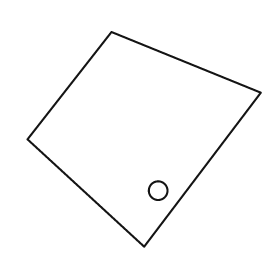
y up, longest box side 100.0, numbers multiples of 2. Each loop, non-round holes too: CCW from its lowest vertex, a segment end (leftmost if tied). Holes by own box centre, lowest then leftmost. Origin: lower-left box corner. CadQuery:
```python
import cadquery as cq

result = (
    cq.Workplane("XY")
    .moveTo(50.0, 0.0)
    .lineTo(100.0, 66.0)
    .lineTo(36.0, 92.0)
    .lineTo(0.0, 46.0)
    .close()
    .moveTo(56.0, 24.0)
    .circle(4.0)
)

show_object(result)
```